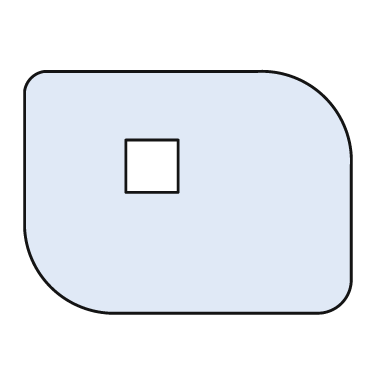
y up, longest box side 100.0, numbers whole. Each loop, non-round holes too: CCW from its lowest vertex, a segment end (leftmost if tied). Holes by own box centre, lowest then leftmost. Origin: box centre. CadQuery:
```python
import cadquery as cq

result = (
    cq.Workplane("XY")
    .moveTo(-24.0, -37.0)
    .lineTo(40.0, -37.0)
    .threePointArc((47.0, -34.0), (50.0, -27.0))
    .lineTo(50.0, 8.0)
    .threePointArc((42.0, 29.0), (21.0, 37.0))
    .lineTo(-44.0, 37.0)
    .threePointArc((-48.0, 35.0), (-50.0, 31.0))
    .lineTo(-50.0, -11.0)
    .threePointArc((-42.0, -29.0), (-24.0, -37.0))
    .close()
    .moveTo(-19.0, 0.0)
    .lineTo(-3.0, 0.0)
    .lineTo(-3.0, 16.0)
    .lineTo(-19.0, 16.0)
    .close()
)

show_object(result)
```